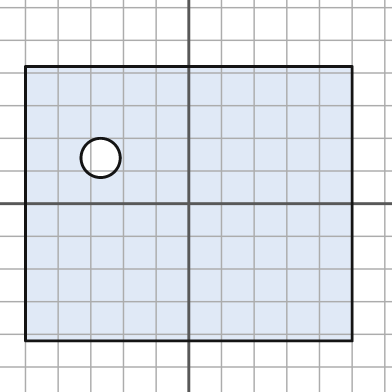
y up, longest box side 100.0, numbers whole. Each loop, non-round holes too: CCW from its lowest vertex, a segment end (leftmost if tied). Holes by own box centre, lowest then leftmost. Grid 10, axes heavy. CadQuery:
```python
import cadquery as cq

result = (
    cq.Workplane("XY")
    .moveTo(-50.0, -42.0)
    .lineTo(50.0, -42.0)
    .lineTo(50.0, 42.0)
    .lineTo(-50.0, 42.0)
    .close()
    .moveTo(-27.0, 14.0)
    .circle(6.0)
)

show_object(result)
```